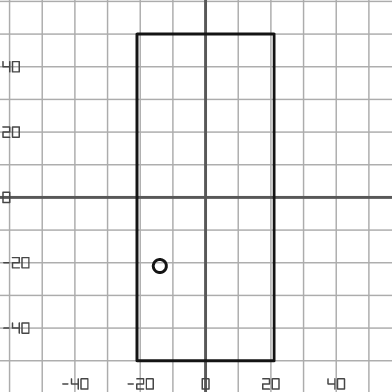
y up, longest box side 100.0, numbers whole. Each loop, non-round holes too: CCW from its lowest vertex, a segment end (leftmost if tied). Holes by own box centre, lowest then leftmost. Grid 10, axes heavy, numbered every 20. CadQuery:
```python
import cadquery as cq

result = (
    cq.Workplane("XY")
    .moveTo(-21.0, -50.0)
    .lineTo(21.0, -50.0)
    .lineTo(21.0, 50.0)
    .lineTo(-21.0, 50.0)
    .close()
    .moveTo(-14.0, -21.0)
    .circle(2.0)
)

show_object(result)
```